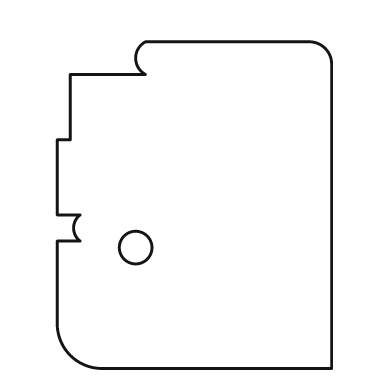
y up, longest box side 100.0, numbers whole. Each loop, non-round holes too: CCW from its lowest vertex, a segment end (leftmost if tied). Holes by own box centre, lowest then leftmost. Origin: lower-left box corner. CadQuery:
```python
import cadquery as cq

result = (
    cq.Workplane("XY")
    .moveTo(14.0, 0.0)
    .lineTo(84.0, 0.0)
    .lineTo(84.0, 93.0)
    .threePointArc((82.0, 98.0), (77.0, 100.0))
    .lineTo(27.0, 100.0)
    .threePointArc((24.0, 95.0), (27.0, 90.0))
    .lineTo(4.0, 90.0)
    .lineTo(4.0, 70.0)
    .lineTo(0.0, 70.0)
    .lineTo(0.0, 47.0)
    .lineTo(7.0, 47.0)
    .threePointArc((5.0, 43.0), (7.0, 39.0))
    .lineTo(0.0, 39.0)
    .lineTo(0.0, 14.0)
    .threePointArc((4.0, 4.0), (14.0, 0.0))
    .close()
    .moveTo(24.0, 37.0)
    .circle(5.0)
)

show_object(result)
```